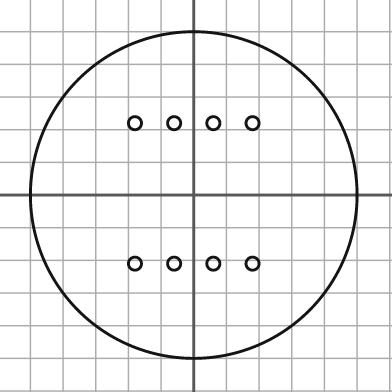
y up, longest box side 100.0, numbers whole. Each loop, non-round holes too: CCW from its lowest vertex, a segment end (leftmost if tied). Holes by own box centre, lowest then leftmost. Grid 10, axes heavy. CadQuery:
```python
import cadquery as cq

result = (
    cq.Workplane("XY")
    .moveTo(0.0, 0.0)
    .circle(50.0)
    .moveTo(-18.0, -21.0)
    .circle(2.0)
    .moveTo(-6.0, -21.0)
    .circle(2.0)
    .moveTo(6.0, -21.0)
    .circle(2.0)
    .moveTo(18.0, -21.0)
    .circle(2.0)
    .moveTo(-18.0, 22.0)
    .circle(2.0)
    .moveTo(-6.0, 22.0)
    .circle(2.0)
    .moveTo(6.0, 22.0)
    .circle(2.0)
    .moveTo(18.0, 22.0)
    .circle(2.0)
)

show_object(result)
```